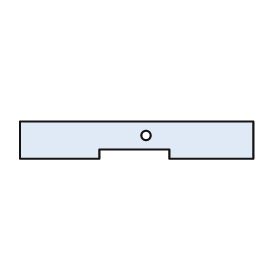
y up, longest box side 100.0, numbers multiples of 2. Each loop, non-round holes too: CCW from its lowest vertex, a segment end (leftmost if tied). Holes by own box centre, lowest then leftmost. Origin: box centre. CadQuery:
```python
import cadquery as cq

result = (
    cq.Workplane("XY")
    .moveTo(-50.0, -8.0)
    .lineTo(-16.0, -8.0)
    .lineTo(-16.0, -4.0)
    .lineTo(14.0, -4.0)
    .lineTo(14.0, -8.0)
    .lineTo(50.0, -8.0)
    .lineTo(50.0, 8.0)
    .lineTo(-50.0, 8.0)
    .close()
    .moveTo(4.0, 2.0)
    .circle(2.0)
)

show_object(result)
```